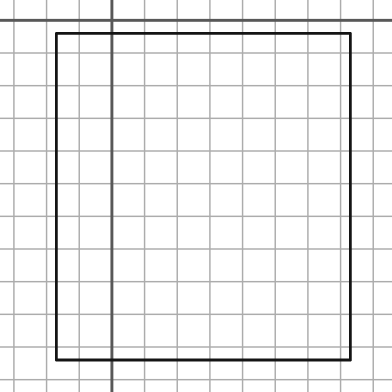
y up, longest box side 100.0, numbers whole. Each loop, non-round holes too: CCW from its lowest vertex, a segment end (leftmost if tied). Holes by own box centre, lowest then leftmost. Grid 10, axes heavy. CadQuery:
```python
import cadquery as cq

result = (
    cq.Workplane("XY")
    .moveTo(-17.0, -104.0)
    .lineTo(73.0, -104.0)
    .lineTo(73.0, -4.0)
    .lineTo(-17.0, -4.0)
    .close()
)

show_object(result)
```